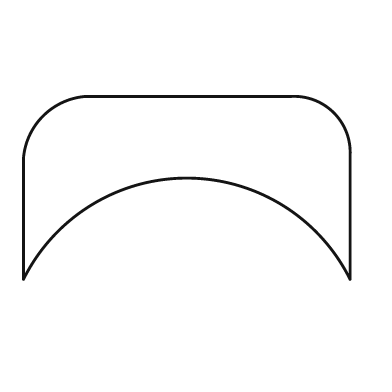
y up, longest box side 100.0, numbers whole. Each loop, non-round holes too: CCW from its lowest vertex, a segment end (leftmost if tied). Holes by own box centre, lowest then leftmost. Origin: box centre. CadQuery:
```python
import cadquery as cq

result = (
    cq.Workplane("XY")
    .moveTo(-50.0, -28.0)
    .threePointArc((0.0, 3.0), (50.0, -28.0))
    .lineTo(50.0, 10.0)
    .threePointArc((45.0, 23.0), (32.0, 28.0))
    .lineTo(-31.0, 28.0)
    .threePointArc((-44.0, 22.0), (-50.0, 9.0))
    .close()
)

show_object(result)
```